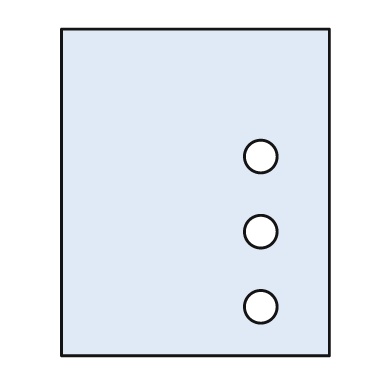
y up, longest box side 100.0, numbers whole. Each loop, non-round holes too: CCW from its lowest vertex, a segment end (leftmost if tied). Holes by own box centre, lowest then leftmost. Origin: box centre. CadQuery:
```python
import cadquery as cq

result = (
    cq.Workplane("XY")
    .moveTo(-41.0, -50.0)
    .lineTo(41.0, -50.0)
    .lineTo(41.0, 50.0)
    .lineTo(-41.0, 50.0)
    .close()
    .moveTo(20.0, -35.0)
    .circle(5.0)
    .moveTo(20.0, -12.0)
    .circle(5.0)
    .moveTo(20.0, 11.0)
    .circle(5.0)
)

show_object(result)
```